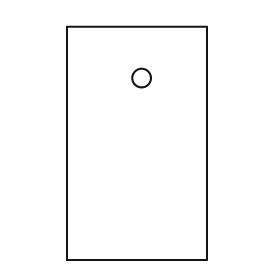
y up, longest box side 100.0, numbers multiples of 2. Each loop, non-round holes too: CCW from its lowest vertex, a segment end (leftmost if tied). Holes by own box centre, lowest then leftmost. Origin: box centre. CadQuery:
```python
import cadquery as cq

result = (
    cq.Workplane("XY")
    .moveTo(-30.0, -50.0)
    .lineTo(30.0, -50.0)
    .lineTo(30.0, 50.0)
    .lineTo(-30.0, 50.0)
    .close()
    .moveTo(2.0, 28.0)
    .circle(4.0)
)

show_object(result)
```